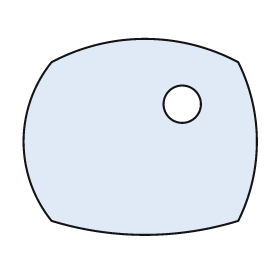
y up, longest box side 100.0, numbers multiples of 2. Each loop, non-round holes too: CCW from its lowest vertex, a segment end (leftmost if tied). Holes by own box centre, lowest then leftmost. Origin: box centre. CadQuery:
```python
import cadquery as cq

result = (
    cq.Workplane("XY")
    .moveTo(-38.0, -36.0)
    .threePointArc((2.0, -42.0), (42.0, -36.0))
    .threePointArc((50.0, -2.0), (42.0, 32.0))
    .threePointArc((2.0, 42.0), (-38.0, 32.0))
    .threePointArc((-50.0, -2.0), (-38.0, -36.0))
    .close()
    .moveTo(18.0, 14.0)
    .circle(8.0)
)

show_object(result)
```